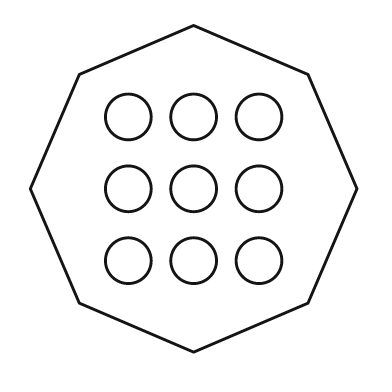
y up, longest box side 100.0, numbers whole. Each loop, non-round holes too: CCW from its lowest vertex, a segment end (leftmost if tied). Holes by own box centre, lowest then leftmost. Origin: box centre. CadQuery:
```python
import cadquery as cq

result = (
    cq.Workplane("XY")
    .moveTo(0.0, -50.0)
    .lineTo(35.0, -35.0)
    .lineTo(50.0, 0.0)
    .lineTo(35.0, 35.0)
    .lineTo(0.0, 50.0)
    .lineTo(-35.0, 35.0)
    .lineTo(-50.0, 0.0)
    .lineTo(-35.0, -35.0)
    .close()
    .moveTo(-20.0, -22.0)
    .circle(7.0)
    .moveTo(0.0, -22.0)
    .circle(7.0)
    .moveTo(20.0, -22.0)
    .circle(7.0)
    .moveTo(-20.0, 0.0)
    .circle(7.0)
    .moveTo(0.0, 0.0)
    .circle(7.0)
    .moveTo(20.0, 0.0)
    .circle(7.0)
    .moveTo(-20.0, 22.0)
    .circle(7.0)
    .moveTo(0.0, 22.0)
    .circle(7.0)
    .moveTo(20.0, 22.0)
    .circle(7.0)
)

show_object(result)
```